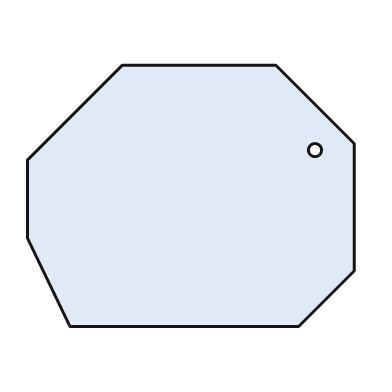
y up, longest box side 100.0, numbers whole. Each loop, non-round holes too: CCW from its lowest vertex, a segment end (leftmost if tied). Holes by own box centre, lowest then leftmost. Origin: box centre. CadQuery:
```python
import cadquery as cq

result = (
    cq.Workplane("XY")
    .moveTo(-37.0, -40.0)
    .lineTo(33.0, -40.0)
    .lineTo(50.0, -23.0)
    .lineTo(50.0, 16.0)
    .lineTo(26.0, 40.0)
    .lineTo(-21.0, 40.0)
    .lineTo(-50.0, 11.0)
    .lineTo(-50.0, -13.0)
    .close()
    .moveTo(38.0, 14.0)
    .circle(2.0)
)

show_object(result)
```